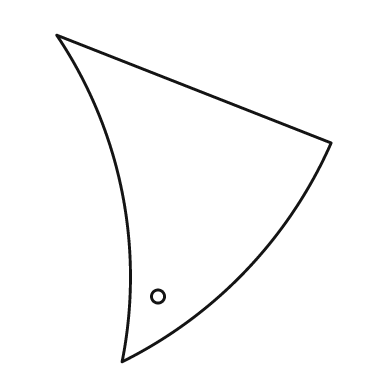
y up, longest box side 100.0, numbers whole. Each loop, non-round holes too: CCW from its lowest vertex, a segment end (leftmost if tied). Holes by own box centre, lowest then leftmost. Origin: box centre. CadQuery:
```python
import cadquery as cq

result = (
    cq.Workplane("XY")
    .moveTo(-22.0, -50.0)
    .threePointArc((16.0, -22.0), (42.0, 17.0))
    .lineTo(-42.0, 50.0)
    .threePointArc((-22.0, 2.0), (-22.0, -50.0))
    .close()
    .moveTo(-11.0, -30.0)
    .circle(2.0)
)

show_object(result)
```